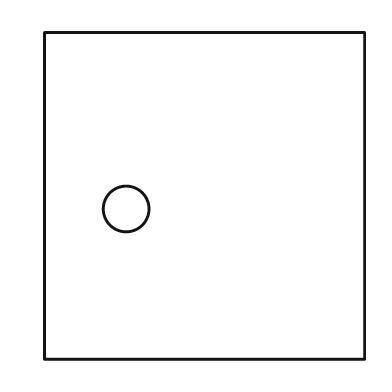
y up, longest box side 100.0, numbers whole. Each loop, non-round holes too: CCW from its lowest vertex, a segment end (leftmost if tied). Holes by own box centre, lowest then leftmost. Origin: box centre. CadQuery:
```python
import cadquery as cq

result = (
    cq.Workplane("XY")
    .moveTo(-49.0, -50.0)
    .lineTo(49.0, -50.0)
    .lineTo(49.0, 50.0)
    .lineTo(-49.0, 50.0)
    .close()
    .moveTo(-24.0, -4.0)
    .circle(7.0)
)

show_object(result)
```